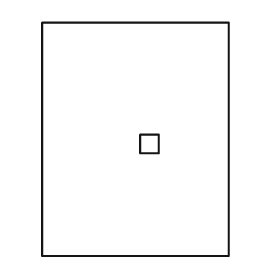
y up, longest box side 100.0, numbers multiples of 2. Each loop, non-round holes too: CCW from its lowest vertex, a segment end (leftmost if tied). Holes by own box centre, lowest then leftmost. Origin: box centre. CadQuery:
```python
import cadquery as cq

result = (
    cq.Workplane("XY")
    .moveTo(-40.0, -50.0)
    .lineTo(40.0, -50.0)
    .lineTo(40.0, 50.0)
    .lineTo(-40.0, 50.0)
    .close()
    .moveTo(2.0, -6.0)
    .lineTo(10.0, -6.0)
    .lineTo(10.0, 2.0)
    .lineTo(2.0, 2.0)
    .close()
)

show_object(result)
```